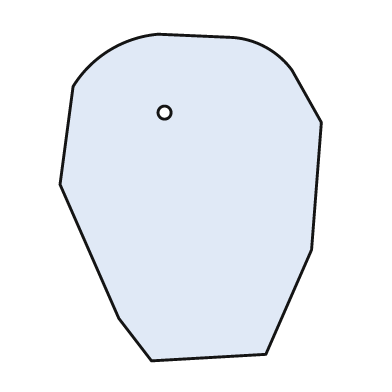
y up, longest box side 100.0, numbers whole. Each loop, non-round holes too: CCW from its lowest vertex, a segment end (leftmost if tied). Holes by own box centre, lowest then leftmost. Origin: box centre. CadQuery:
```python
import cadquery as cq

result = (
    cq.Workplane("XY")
    .moveTo(-12.0, -50.0)
    .lineTo(23.0, -48.0)
    .lineTo(37.0, -16.0)
    .lineTo(40.0, 23.0)
    .lineTo(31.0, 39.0)
    .threePointArc((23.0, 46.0), (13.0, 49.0))
    .lineTo(-10.0, 50.0)
    .threePointArc((-25.0, 45.0), (-36.0, 34.0))
    .lineTo(-40.0, 4.0)
    .lineTo(-22.0, -37.0)
    .close()
    .moveTo(-8.0, 26.0)
    .circle(2.0)
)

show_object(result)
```